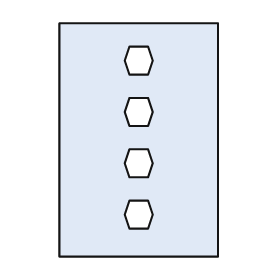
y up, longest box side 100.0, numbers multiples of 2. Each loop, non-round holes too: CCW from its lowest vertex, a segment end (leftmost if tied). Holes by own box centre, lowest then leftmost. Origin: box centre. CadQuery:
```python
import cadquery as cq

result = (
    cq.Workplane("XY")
    .moveTo(-34.0, -50.0)
    .lineTo(34.0, -50.0)
    .lineTo(34.0, 50.0)
    .lineTo(-34.0, 50.0)
    .close()
    .moveTo(-4.0, -38.0)
    .lineTo(4.0, -38.0)
    .lineTo(6.0, -32.0)
    .lineTo(4.0, -26.0)
    .lineTo(-4.0, -26.0)
    .lineTo(-6.0, -32.0)
    .close()
    .moveTo(-4.0, -16.0)
    .lineTo(4.0, -16.0)
    .lineTo(6.0, -10.0)
    .lineTo(4.0, -4.0)
    .lineTo(-4.0, -4.0)
    .lineTo(-6.0, -10.0)
    .close()
    .moveTo(-4.0, 6.0)
    .lineTo(4.0, 6.0)
    .lineTo(6.0, 12.0)
    .lineTo(4.0, 18.0)
    .lineTo(-4.0, 18.0)
    .lineTo(-6.0, 12.0)
    .close()
    .moveTo(-4.0, 28.0)
    .lineTo(4.0, 28.0)
    .lineTo(6.0, 34.0)
    .lineTo(4.0, 40.0)
    .lineTo(-4.0, 40.0)
    .lineTo(-6.0, 34.0)
    .close()
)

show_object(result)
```